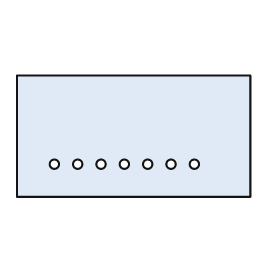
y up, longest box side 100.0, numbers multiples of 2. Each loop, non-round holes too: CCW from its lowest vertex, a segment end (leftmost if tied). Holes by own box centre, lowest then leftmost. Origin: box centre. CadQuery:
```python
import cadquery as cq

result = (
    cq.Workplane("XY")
    .moveTo(-50.0, -26.0)
    .lineTo(50.0, -26.0)
    .lineTo(50.0, 26.0)
    .lineTo(-50.0, 26.0)
    .close()
    .moveTo(-34.0, -12.0)
    .circle(2.0)
    .moveTo(-24.0, -12.0)
    .circle(2.0)
    .moveTo(-14.0, -12.0)
    .circle(2.0)
    .moveTo(-4.0, -12.0)
    .circle(2.0)
    .moveTo(6.0, -12.0)
    .circle(2.0)
    .moveTo(16.0, -12.0)
    .circle(2.0)
    .moveTo(26.0, -12.0)
    .circle(2.0)
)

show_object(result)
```